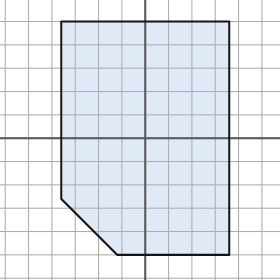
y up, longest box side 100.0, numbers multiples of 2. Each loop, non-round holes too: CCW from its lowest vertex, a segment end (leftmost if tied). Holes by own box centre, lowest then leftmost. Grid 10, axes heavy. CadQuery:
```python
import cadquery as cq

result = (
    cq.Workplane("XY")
    .moveTo(-12.0, -50.0)
    .lineTo(36.0, -50.0)
    .lineTo(36.0, 50.0)
    .lineTo(-36.0, 50.0)
    .lineTo(-36.0, -26.0)
    .close()
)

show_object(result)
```